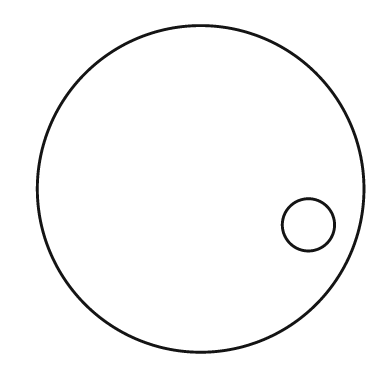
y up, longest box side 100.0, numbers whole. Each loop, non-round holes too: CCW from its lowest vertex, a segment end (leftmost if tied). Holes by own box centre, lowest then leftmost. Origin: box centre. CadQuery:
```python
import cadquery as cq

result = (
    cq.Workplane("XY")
    .moveTo(0.0, 0.0)
    .circle(50.0)
    .moveTo(33.0, -11.0)
    .circle(8.0)
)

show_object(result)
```